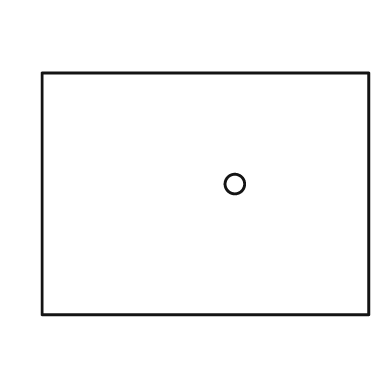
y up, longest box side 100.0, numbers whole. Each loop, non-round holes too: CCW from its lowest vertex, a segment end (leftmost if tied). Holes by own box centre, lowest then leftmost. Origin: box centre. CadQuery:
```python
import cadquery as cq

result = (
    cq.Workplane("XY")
    .moveTo(-50.0, -37.0)
    .lineTo(50.0, -37.0)
    .lineTo(50.0, 37.0)
    .lineTo(-50.0, 37.0)
    .close()
    .moveTo(9.0, 3.0)
    .circle(3.0)
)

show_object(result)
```